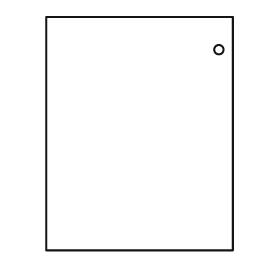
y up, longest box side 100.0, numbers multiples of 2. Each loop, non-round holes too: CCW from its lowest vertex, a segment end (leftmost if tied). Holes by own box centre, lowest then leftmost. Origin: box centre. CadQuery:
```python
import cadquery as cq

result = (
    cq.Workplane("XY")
    .moveTo(-40.0, -50.0)
    .lineTo(40.0, -50.0)
    .lineTo(40.0, 50.0)
    .lineTo(-40.0, 50.0)
    .close()
    .moveTo(34.0, 36.0)
    .circle(2.0)
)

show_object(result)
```